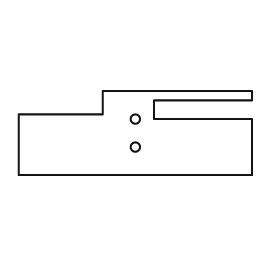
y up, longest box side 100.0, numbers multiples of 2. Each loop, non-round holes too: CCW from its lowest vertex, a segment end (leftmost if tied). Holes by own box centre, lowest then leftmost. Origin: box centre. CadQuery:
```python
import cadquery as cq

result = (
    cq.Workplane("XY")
    .moveTo(-50.0, -18.0)
    .lineTo(50.0, -18.0)
    .lineTo(50.0, 6.0)
    .lineTo(8.0, 6.0)
    .lineTo(8.0, 14.0)
    .lineTo(50.0, 14.0)
    .lineTo(50.0, 18.0)
    .lineTo(-14.0, 18.0)
    .lineTo(-14.0, 8.0)
    .lineTo(-50.0, 8.0)
    .close()
    .moveTo(0.0, -6.0)
    .circle(2.0)
    .moveTo(0.0, 6.0)
    .circle(2.0)
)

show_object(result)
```